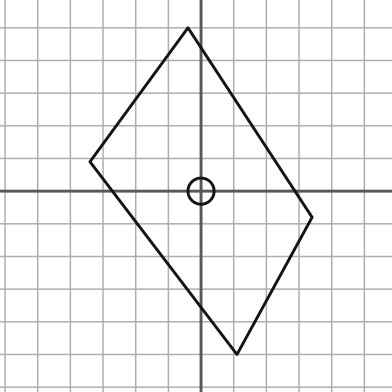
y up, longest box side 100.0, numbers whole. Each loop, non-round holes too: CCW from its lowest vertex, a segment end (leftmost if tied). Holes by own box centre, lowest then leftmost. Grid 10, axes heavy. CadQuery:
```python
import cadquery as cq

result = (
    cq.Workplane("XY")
    .moveTo(11.0, -50.0)
    .lineTo(34.0, -8.0)
    .lineTo(-4.0, 50.0)
    .lineTo(-34.0, 9.0)
    .close()
    .moveTo(0.0, 0.0)
    .circle(4.0)
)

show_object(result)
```